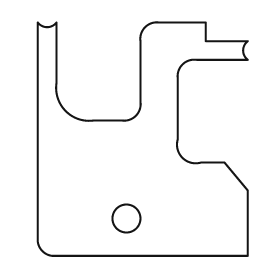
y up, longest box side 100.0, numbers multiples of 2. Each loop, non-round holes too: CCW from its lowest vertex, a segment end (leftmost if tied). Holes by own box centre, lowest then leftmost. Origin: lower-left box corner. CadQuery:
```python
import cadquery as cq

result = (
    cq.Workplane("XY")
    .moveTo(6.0, 0.0)
    .lineTo(90.0, 0.0)
    .lineTo(90.0, 28.0)
    .lineTo(80.0, 40.0)
    .lineTo(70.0, 40.0)
    .threePointArc((62.0, 42.0), (60.0, 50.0))
    .lineTo(60.0, 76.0)
    .threePointArc((62.0, 82.0), (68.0, 84.0))
    .lineTo(90.0, 84.0)
    .threePointArc((88.0, 88.0), (90.0, 92.0))
    .lineTo(72.0, 92.0)
    .lineTo(72.0, 100.0)
    .lineTo(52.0, 100.0)
    .threePointArc((46.0, 98.0), (44.0, 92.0))
    .lineTo(44.0, 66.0)
    .threePointArc((42.0, 60.0), (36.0, 58.0))
    .lineTo(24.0, 58.0)
    .threePointArc((12.0, 62.0), (8.0, 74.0))
    .lineTo(8.0, 100.0)
    .threePointArc((4.0, 98.0), (0.0, 100.0))
    .lineTo(0.0, 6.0)
    .threePointArc((2.0, 2.0), (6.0, 0.0))
    .close()
    .moveTo(38.0, 16.0)
    .circle(6.0)
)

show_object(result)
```